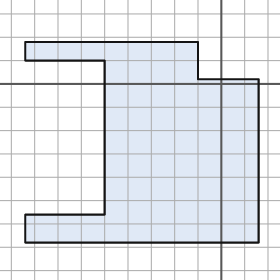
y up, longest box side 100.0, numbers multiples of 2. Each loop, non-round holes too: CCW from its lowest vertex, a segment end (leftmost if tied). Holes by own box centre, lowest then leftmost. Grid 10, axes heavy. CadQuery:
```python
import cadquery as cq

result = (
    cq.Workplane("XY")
    .moveTo(-84.0, -68.0)
    .lineTo(16.0, -68.0)
    .lineTo(16.0, 2.0)
    .lineTo(-10.0, 2.0)
    .lineTo(-10.0, 18.0)
    .lineTo(-84.0, 18.0)
    .lineTo(-84.0, 10.0)
    .lineTo(-50.0, 10.0)
    .lineTo(-50.0, -56.0)
    .lineTo(-84.0, -56.0)
    .close()
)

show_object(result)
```